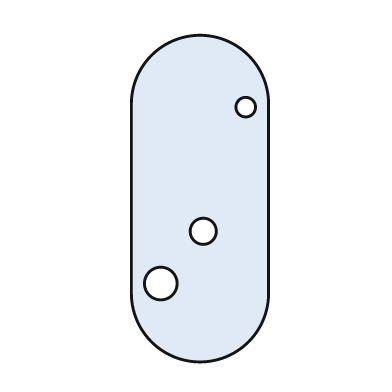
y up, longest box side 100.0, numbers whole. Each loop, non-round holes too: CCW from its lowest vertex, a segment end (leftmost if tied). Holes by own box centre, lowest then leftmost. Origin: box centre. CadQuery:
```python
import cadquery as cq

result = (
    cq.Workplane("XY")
    .moveTo(-21.0, -29.0)
    .threePointArc((0.0, -50.0), (21.0, -29.0))
    .lineTo(21.0, 29.0)
    .threePointArc((0.0, 50.0), (-21.0, 29.0))
    .close()
    .moveTo(-12.0, -26.0)
    .circle(5.0)
    .moveTo(1.0, -10.0)
    .circle(4.0)
    .moveTo(14.0, 28.0)
    .circle(3.0)
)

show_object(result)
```